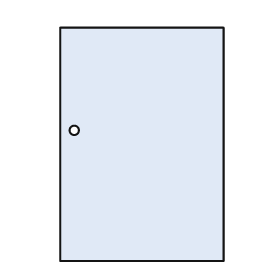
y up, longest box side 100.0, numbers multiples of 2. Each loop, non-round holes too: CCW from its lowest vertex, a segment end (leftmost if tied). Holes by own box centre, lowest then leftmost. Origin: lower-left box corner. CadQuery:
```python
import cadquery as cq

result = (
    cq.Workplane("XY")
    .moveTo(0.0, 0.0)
    .lineTo(70.0, 0.0)
    .lineTo(70.0, 100.0)
    .lineTo(0.0, 100.0)
    .close()
    .moveTo(6.0, 56.0)
    .circle(2.0)
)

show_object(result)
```